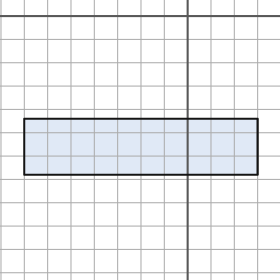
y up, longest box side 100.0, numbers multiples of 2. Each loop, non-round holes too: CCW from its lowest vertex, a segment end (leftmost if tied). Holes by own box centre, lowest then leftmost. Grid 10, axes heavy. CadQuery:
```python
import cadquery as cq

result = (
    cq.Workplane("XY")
    .moveTo(-70.0, -68.0)
    .lineTo(30.0, -68.0)
    .lineTo(30.0, -44.0)
    .lineTo(-70.0, -44.0)
    .close()
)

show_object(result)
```